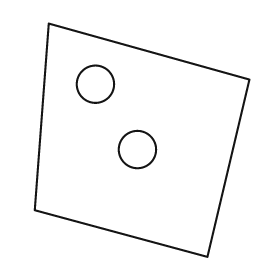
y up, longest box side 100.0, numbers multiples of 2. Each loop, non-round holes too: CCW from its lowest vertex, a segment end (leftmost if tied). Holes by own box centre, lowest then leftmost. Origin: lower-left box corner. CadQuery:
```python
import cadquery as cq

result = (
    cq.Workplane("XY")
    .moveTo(74.0, 0.0)
    .lineTo(92.0, 76.0)
    .lineTo(6.0, 100.0)
    .lineTo(0.0, 20.0)
    .close()
    .moveTo(44.0, 46.0)
    .circle(8.0)
    .moveTo(26.0, 74.0)
    .circle(8.0)
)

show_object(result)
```